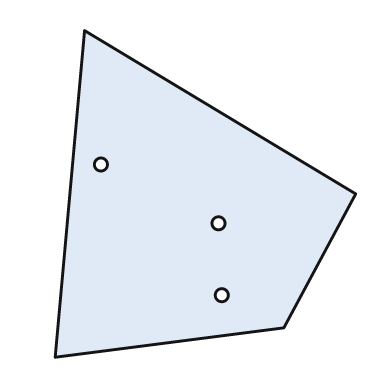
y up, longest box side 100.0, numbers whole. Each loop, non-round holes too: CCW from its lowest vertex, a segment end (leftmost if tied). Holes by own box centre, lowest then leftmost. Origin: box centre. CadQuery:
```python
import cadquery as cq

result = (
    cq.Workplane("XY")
    .moveTo(-46.0, -50.0)
    .lineTo(24.0, -41.0)
    .lineTo(46.0, 0.0)
    .lineTo(-37.0, 50.0)
    .close()
    .moveTo(5.0, -31.0)
    .circle(2.0)
    .moveTo(4.0, -9.0)
    .circle(2.0)
    .moveTo(-32.0, 9.0)
    .circle(2.0)
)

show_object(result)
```